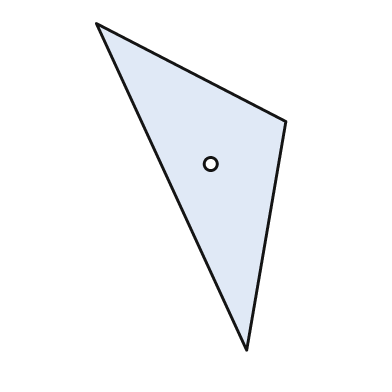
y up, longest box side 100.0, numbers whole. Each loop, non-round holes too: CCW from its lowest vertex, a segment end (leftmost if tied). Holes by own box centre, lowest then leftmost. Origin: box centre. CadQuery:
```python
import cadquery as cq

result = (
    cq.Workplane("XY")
    .moveTo(17.0, -50.0)
    .lineTo(29.0, 20.0)
    .lineTo(-29.0, 50.0)
    .close()
    .moveTo(6.0, 7.0)
    .circle(2.0)
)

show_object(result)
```